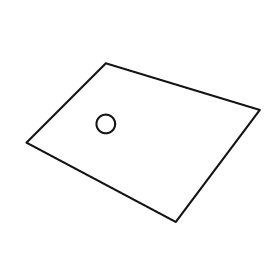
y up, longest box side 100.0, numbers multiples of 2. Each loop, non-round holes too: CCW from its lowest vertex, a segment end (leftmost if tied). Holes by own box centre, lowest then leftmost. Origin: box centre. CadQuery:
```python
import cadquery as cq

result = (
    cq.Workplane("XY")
    .moveTo(14.0, -34.0)
    .lineTo(50.0, 14.0)
    .lineTo(-16.0, 34.0)
    .lineTo(-50.0, 0.0)
    .close()
    .moveTo(-16.0, 8.0)
    .circle(4.0)
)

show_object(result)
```